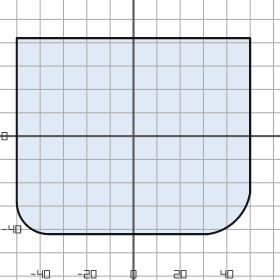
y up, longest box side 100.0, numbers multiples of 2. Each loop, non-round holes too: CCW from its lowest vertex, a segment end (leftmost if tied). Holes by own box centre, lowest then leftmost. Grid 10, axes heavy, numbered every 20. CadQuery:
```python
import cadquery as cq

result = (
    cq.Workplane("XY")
    .moveTo(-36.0, -42.0)
    .lineTo(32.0, -42.0)
    .threePointArc((44.0, -36.0), (50.0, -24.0))
    .lineTo(50.0, 42.0)
    .lineTo(-50.0, 42.0)
    .lineTo(-50.0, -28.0)
    .threePointArc((-46.0, -38.0), (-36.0, -42.0))
    .close()
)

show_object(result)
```